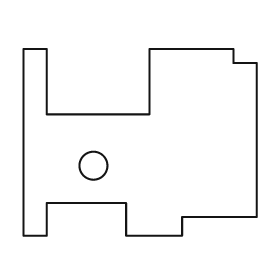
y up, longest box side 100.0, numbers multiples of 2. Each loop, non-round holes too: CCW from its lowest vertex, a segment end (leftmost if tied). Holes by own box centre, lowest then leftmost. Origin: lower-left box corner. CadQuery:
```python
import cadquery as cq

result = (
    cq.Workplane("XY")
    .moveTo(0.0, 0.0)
    .lineTo(10.0, 0.0)
    .lineTo(10.0, 14.0)
    .lineTo(44.0, 14.0)
    .lineTo(44.0, 0.0)
    .lineTo(68.0, 0.0)
    .lineTo(68.0, 8.0)
    .lineTo(100.0, 8.0)
    .lineTo(100.0, 74.0)
    .lineTo(90.0, 74.0)
    .lineTo(90.0, 80.0)
    .lineTo(54.0, 80.0)
    .lineTo(54.0, 52.0)
    .lineTo(10.0, 52.0)
    .lineTo(10.0, 80.0)
    .lineTo(0.0, 80.0)
    .close()
    .moveTo(30.0, 30.0)
    .circle(6.0)
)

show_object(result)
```